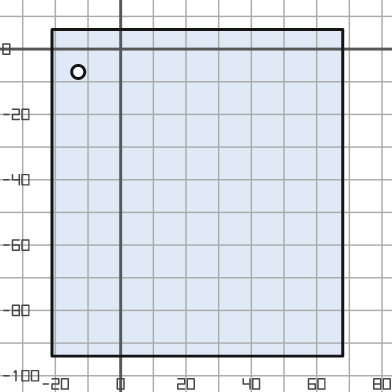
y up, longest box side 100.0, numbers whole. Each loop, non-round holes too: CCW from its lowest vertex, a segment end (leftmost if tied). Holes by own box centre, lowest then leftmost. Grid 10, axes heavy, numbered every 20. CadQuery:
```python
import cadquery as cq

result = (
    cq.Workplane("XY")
    .moveTo(-21.0, -94.0)
    .lineTo(68.0, -94.0)
    .lineTo(68.0, 6.0)
    .lineTo(-21.0, 6.0)
    .close()
    .moveTo(-13.0, -7.0)
    .circle(2.0)
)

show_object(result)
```